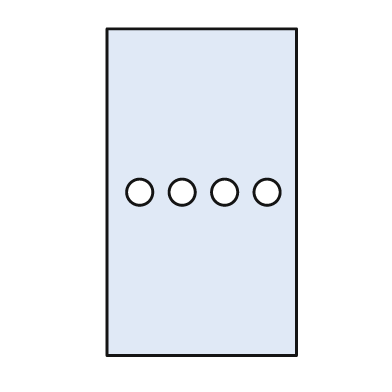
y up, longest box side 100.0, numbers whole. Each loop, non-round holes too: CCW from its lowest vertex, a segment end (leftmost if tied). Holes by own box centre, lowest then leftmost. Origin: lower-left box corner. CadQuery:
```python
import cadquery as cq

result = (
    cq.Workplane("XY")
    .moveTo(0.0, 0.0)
    .lineTo(58.0, 0.0)
    .lineTo(58.0, 100.0)
    .lineTo(0.0, 100.0)
    .close()
    .moveTo(10.0, 50.0)
    .circle(4.0)
    .moveTo(23.0, 50.0)
    .circle(4.0)
    .moveTo(36.0, 50.0)
    .circle(4.0)
    .moveTo(49.0, 50.0)
    .circle(4.0)
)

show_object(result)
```